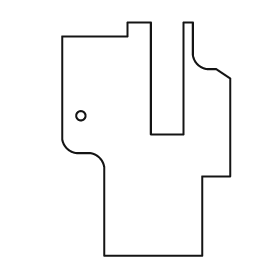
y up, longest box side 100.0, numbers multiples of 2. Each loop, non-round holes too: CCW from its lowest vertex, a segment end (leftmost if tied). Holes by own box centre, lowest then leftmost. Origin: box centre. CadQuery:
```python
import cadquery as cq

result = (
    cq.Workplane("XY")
    .moveTo(-18.0, -50.0)
    .lineTo(24.0, -50.0)
    .lineTo(24.0, -16.0)
    .lineTo(36.0, -16.0)
    .lineTo(36.0, 26.0)
    .lineTo(30.0, 30.0)
    .lineTo(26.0, 30.0)
    .threePointArc((22.0, 32.0), (20.0, 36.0))
    .lineTo(20.0, 50.0)
    .lineTo(16.0, 50.0)
    .lineTo(16.0, 2.0)
    .lineTo(2.0, 2.0)
    .lineTo(2.0, 50.0)
    .lineTo(-8.0, 50.0)
    .lineTo(-8.0, 44.0)
    .lineTo(-36.0, 44.0)
    .lineTo(-36.0, 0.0)
    .threePointArc((-34.0, -4.0), (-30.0, -6.0))
    .lineTo(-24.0, -6.0)
    .threePointArc((-20.0, -8.0), (-18.0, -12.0))
    .close()
    .moveTo(-28.0, 10.0)
    .circle(2.0)
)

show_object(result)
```